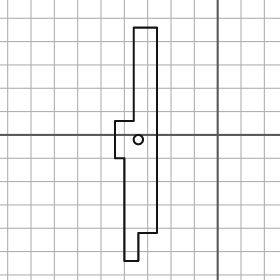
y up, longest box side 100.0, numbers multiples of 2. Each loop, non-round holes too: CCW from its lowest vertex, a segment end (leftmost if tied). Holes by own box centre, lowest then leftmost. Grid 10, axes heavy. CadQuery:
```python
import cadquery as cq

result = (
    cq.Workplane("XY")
    .moveTo(-40.0, -54.0)
    .lineTo(-34.0, -54.0)
    .lineTo(-34.0, -42.0)
    .lineTo(-26.0, -42.0)
    .lineTo(-26.0, 46.0)
    .lineTo(-36.0, 46.0)
    .lineTo(-36.0, 6.0)
    .lineTo(-44.0, 6.0)
    .lineTo(-44.0, -10.0)
    .lineTo(-40.0, -10.0)
    .close()
    .moveTo(-34.0, -2.0)
    .circle(2.0)
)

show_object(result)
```